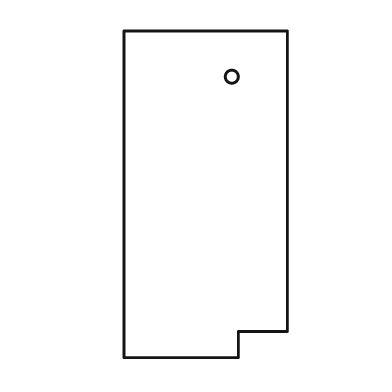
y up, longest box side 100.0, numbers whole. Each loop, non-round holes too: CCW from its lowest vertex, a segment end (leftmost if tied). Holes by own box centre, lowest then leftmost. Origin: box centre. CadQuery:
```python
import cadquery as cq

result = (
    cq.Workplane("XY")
    .moveTo(-25.0, -50.0)
    .lineTo(10.0, -50.0)
    .lineTo(10.0, -42.0)
    .lineTo(25.0, -42.0)
    .lineTo(25.0, 50.0)
    .lineTo(-25.0, 50.0)
    .close()
    .moveTo(8.0, 36.0)
    .circle(2.0)
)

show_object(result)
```